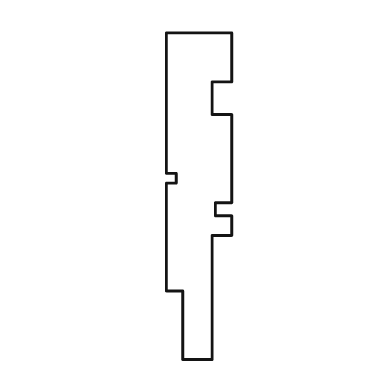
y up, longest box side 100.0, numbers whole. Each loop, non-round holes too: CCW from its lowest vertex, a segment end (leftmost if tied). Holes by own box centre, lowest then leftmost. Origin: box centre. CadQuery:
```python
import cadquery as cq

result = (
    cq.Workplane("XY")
    .moveTo(-5.0, -50.0)
    .lineTo(4.0, -50.0)
    .lineTo(4.0, -12.0)
    .lineTo(10.0, -12.0)
    .lineTo(10.0, -6.0)
    .lineTo(5.0, -6.0)
    .lineTo(5.0, -2.0)
    .lineTo(10.0, -2.0)
    .lineTo(10.0, 25.0)
    .lineTo(4.0, 25.0)
    .lineTo(4.0, 35.0)
    .lineTo(10.0, 35.0)
    .lineTo(10.0, 50.0)
    .lineTo(-10.0, 50.0)
    .lineTo(-10.0, 7.0)
    .lineTo(-7.0, 7.0)
    .lineTo(-7.0, 4.0)
    .lineTo(-10.0, 4.0)
    .lineTo(-10.0, -29.0)
    .lineTo(-5.0, -29.0)
    .close()
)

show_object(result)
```